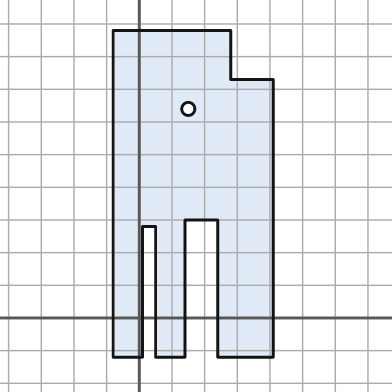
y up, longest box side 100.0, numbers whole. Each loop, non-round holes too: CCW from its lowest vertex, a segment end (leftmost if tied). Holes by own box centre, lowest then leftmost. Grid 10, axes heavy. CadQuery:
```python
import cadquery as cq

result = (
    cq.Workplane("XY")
    .moveTo(-8.0, -12.0)
    .lineTo(1.0, -12.0)
    .lineTo(1.0, 28.0)
    .lineTo(5.0, 28.0)
    .lineTo(5.0, -12.0)
    .lineTo(14.0, -12.0)
    .lineTo(14.0, 30.0)
    .lineTo(24.0, 30.0)
    .lineTo(24.0, -12.0)
    .lineTo(41.0, -12.0)
    .lineTo(41.0, 73.0)
    .lineTo(28.0, 73.0)
    .lineTo(28.0, 88.0)
    .lineTo(-8.0, 88.0)
    .close()
    .moveTo(15.0, 64.0)
    .circle(2.0)
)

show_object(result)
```